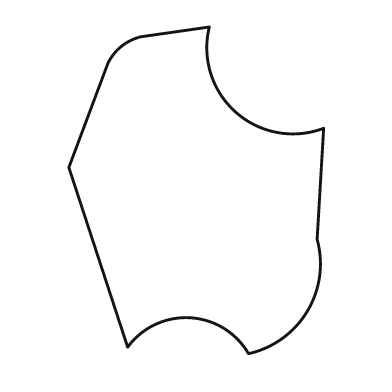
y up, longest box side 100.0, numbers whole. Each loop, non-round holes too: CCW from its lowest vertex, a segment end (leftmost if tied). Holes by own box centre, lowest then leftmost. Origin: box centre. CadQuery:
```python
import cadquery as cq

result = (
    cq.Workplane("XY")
    .moveTo(16.0, -50.0)
    .threePointArc((34.0, -37.0), (37.0, -15.0))
    .lineTo(39.0, 19.0)
    .threePointArc((12.0, 24.0), (4.0, 50.0))
    .lineTo(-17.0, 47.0)
    .threePointArc((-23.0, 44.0), (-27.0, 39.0))
    .lineTo(-39.0, 7.0)
    .lineTo(-21.0, -48.0)
    .threePointArc((-2.0, -39.0), (16.0, -50.0))
    .close()
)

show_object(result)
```